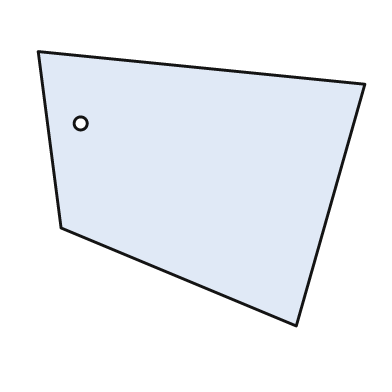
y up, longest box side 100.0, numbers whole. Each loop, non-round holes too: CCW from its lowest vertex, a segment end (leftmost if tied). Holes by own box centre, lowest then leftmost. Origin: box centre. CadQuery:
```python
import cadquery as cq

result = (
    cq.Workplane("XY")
    .moveTo(29.0, -42.0)
    .lineTo(50.0, 32.0)
    .lineTo(-50.0, 42.0)
    .lineTo(-43.0, -12.0)
    .close()
    .moveTo(-37.0, 20.0)
    .circle(2.0)
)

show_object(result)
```